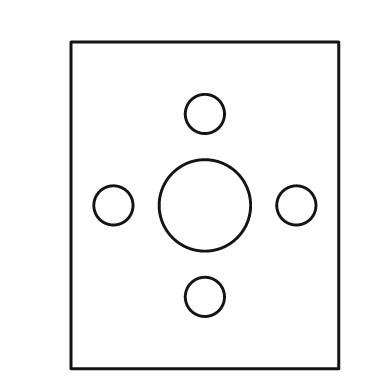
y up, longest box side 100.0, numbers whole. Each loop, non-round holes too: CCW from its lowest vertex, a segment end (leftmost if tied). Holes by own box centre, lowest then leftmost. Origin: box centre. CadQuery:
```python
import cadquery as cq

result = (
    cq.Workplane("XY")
    .moveTo(-41.0, -50.0)
    .lineTo(41.0, -50.0)
    .lineTo(41.0, 50.0)
    .lineTo(-41.0, 50.0)
    .close()
    .moveTo(0.0, -28.0)
    .circle(6.0)
    .moveTo(-28.0, 0.0)
    .circle(6.0)
    .moveTo(0.0, 0.0)
    .circle(14.0)
    .moveTo(28.0, 0.0)
    .circle(6.0)
    .moveTo(0.0, 28.0)
    .circle(6.0)
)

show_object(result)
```